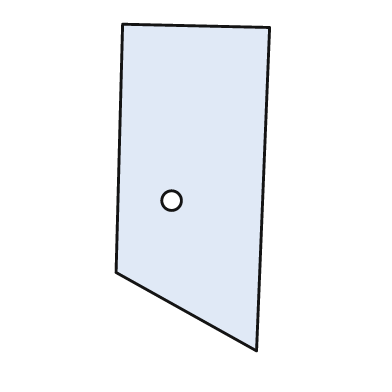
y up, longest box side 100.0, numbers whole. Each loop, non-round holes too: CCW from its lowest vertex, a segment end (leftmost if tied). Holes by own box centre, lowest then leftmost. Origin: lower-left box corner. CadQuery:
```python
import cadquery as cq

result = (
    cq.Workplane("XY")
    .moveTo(43.0, 0.0)
    .lineTo(47.0, 99.0)
    .lineTo(2.0, 100.0)
    .lineTo(0.0, 24.0)
    .close()
    .moveTo(17.0, 46.0)
    .circle(3.0)
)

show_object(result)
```